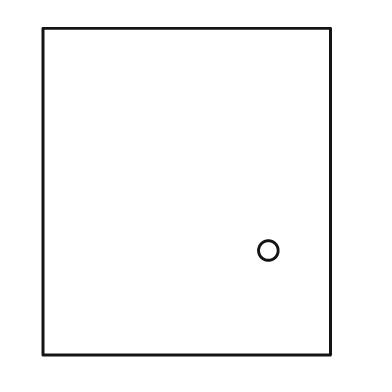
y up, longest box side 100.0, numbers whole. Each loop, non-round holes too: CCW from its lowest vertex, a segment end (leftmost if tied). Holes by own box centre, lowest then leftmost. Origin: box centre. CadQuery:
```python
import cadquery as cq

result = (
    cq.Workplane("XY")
    .moveTo(-44.0, -50.0)
    .lineTo(44.0, -50.0)
    .lineTo(44.0, 50.0)
    .lineTo(-44.0, 50.0)
    .close()
    .moveTo(25.0, -18.0)
    .circle(3.0)
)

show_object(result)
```